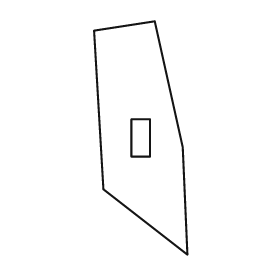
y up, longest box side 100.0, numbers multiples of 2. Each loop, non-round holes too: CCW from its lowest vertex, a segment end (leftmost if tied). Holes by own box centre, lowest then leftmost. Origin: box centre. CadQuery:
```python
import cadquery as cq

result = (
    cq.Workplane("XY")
    .moveTo(20.0, -50.0)
    .lineTo(18.0, -4.0)
    .lineTo(6.0, 50.0)
    .lineTo(-20.0, 46.0)
    .lineTo(-16.0, -22.0)
    .close()
    .moveTo(-4.0, -8.0)
    .lineTo(4.0, -8.0)
    .lineTo(4.0, 8.0)
    .lineTo(-4.0, 8.0)
    .close()
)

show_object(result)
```